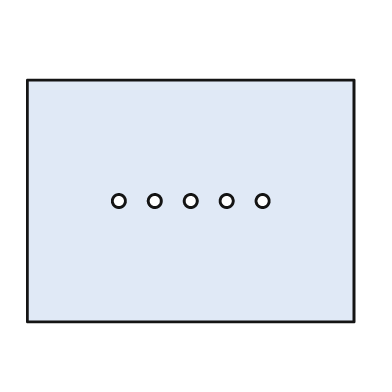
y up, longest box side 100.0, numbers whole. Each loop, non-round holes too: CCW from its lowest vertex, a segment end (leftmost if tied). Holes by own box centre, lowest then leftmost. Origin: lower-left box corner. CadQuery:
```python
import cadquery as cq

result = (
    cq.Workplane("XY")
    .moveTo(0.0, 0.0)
    .lineTo(100.0, 0.0)
    .lineTo(100.0, 74.0)
    .lineTo(0.0, 74.0)
    .close()
    .moveTo(28.0, 37.0)
    .circle(2.0)
    .moveTo(39.0, 37.0)
    .circle(2.0)
    .moveTo(50.0, 37.0)
    .circle(2.0)
    .moveTo(61.0, 37.0)
    .circle(2.0)
    .moveTo(72.0, 37.0)
    .circle(2.0)
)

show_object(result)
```